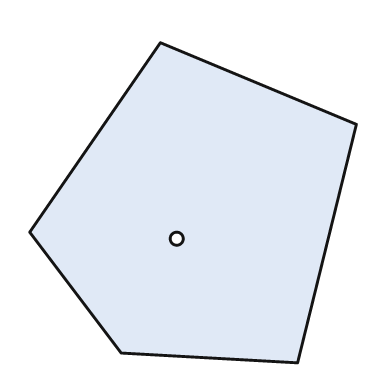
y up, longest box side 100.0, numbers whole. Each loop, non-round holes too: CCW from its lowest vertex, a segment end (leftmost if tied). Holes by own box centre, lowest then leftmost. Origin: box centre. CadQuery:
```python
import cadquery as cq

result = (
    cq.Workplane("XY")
    .moveTo(32.0, -49.0)
    .lineTo(50.0, 24.0)
    .lineTo(-10.0, 49.0)
    .lineTo(-50.0, -9.0)
    .lineTo(-22.0, -46.0)
    .close()
    .moveTo(-5.0, -11.0)
    .circle(2.0)
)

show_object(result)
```